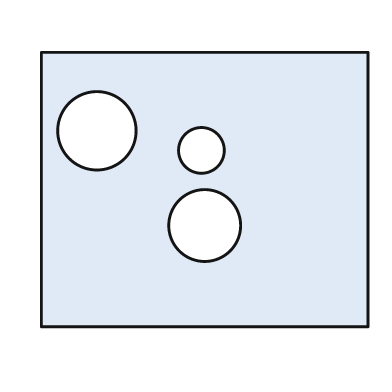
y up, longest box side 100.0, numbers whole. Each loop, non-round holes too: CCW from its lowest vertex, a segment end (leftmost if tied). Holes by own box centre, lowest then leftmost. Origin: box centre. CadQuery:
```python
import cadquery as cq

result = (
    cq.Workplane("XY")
    .moveTo(-50.0, -42.0)
    .lineTo(50.0, -42.0)
    .lineTo(50.0, 42.0)
    .lineTo(-50.0, 42.0)
    .close()
    .moveTo(0.0, -11.0)
    .circle(11.0)
    .moveTo(-1.0, 12.0)
    .circle(7.0)
    .moveTo(-33.0, 18.0)
    .circle(12.0)
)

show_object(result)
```